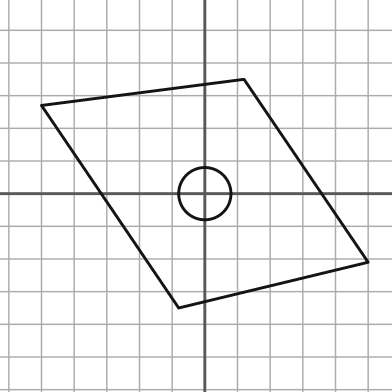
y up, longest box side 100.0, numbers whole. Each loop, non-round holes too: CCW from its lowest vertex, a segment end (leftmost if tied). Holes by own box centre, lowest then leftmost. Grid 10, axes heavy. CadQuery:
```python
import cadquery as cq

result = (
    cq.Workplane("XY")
    .moveTo(-8.0, -35.0)
    .lineTo(50.0, -21.0)
    .lineTo(12.0, 35.0)
    .lineTo(-50.0, 27.0)
    .close()
    .moveTo(0.0, 0.0)
    .circle(8.0)
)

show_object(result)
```